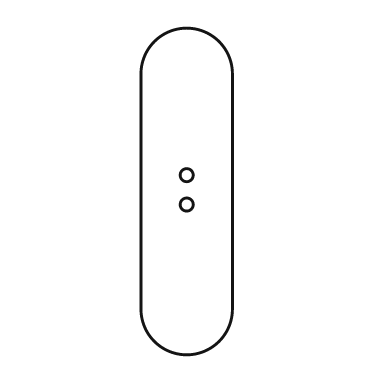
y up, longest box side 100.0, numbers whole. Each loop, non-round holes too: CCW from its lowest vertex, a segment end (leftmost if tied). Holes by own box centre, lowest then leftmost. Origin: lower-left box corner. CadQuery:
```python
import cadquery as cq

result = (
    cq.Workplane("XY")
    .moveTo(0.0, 14.0)
    .threePointArc((14.0, 0.0), (28.0, 14.0))
    .lineTo(28.0, 86.0)
    .threePointArc((14.0, 100.0), (0.0, 86.0))
    .close()
    .moveTo(14.0, 46.0)
    .circle(2.0)
    .moveTo(14.0, 55.0)
    .circle(2.0)
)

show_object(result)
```